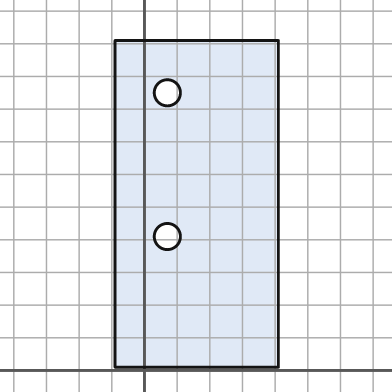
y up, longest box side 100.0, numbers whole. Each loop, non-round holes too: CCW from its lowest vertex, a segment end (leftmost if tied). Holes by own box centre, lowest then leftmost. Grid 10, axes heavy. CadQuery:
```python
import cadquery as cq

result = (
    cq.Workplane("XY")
    .moveTo(-9.0, 1.0)
    .lineTo(41.0, 1.0)
    .lineTo(41.0, 101.0)
    .lineTo(-9.0, 101.0)
    .close()
    .moveTo(7.0, 41.0)
    .circle(4.0)
    .moveTo(7.0, 85.0)
    .circle(4.0)
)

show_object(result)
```